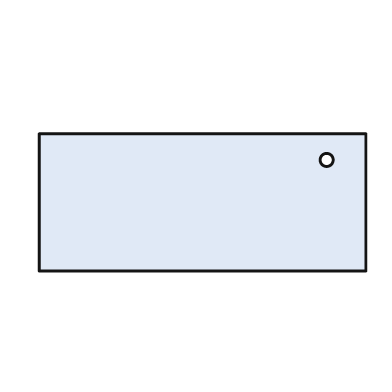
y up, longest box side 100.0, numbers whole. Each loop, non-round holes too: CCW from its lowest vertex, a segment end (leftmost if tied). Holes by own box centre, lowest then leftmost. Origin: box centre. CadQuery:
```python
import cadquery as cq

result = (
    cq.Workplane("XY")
    .moveTo(-50.0, -21.0)
    .lineTo(50.0, -21.0)
    .lineTo(50.0, 21.0)
    .lineTo(-50.0, 21.0)
    .close()
    .moveTo(38.0, 13.0)
    .circle(2.0)
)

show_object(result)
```